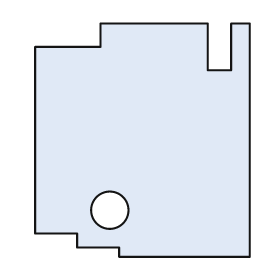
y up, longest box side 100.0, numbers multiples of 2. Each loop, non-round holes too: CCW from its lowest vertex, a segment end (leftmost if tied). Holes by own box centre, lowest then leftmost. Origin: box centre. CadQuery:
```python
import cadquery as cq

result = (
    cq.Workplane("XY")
    .moveTo(-10.0, -50.0)
    .lineTo(46.0, -50.0)
    .lineTo(46.0, 50.0)
    .lineTo(38.0, 50.0)
    .lineTo(38.0, 30.0)
    .lineTo(28.0, 30.0)
    .lineTo(28.0, 50.0)
    .lineTo(-18.0, 50.0)
    .lineTo(-18.0, 40.0)
    .lineTo(-46.0, 40.0)
    .lineTo(-46.0, -40.0)
    .lineTo(-28.0, -40.0)
    .lineTo(-28.0, -46.0)
    .lineTo(-10.0, -46.0)
    .close()
    .moveTo(-14.0, -30.0)
    .circle(8.0)
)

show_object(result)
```